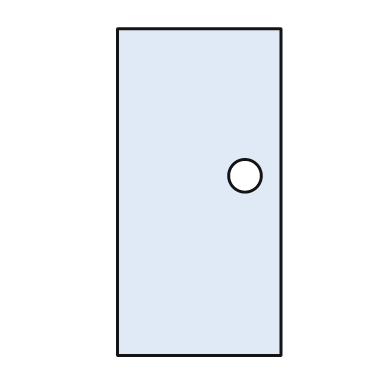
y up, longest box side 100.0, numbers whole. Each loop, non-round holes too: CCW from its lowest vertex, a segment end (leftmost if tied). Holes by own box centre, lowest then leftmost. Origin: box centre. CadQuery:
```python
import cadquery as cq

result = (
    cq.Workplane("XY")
    .moveTo(-25.0, -50.0)
    .lineTo(25.0, -50.0)
    .lineTo(25.0, 50.0)
    .lineTo(-25.0, 50.0)
    .close()
    .moveTo(14.0, 5.0)
    .circle(5.0)
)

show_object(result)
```